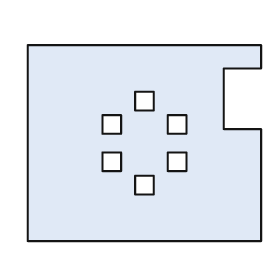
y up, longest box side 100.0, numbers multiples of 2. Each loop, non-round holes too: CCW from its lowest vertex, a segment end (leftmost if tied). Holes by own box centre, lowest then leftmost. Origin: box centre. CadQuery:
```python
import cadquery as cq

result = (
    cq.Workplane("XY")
    .moveTo(-50.0, -42.0)
    .lineTo(50.0, -42.0)
    .lineTo(50.0, 6.0)
    .lineTo(34.0, 6.0)
    .lineTo(34.0, 32.0)
    .lineTo(50.0, 32.0)
    .lineTo(50.0, 42.0)
    .lineTo(-50.0, 42.0)
    .close()
    .moveTo(-4.0, -22.0)
    .lineTo(4.0, -22.0)
    .lineTo(4.0, -14.0)
    .lineTo(-4.0, -14.0)
    .close()
    .moveTo(-18.0, -12.0)
    .lineTo(-10.0, -12.0)
    .lineTo(-10.0, -4.0)
    .lineTo(-18.0, -4.0)
    .close()
    .moveTo(10.0, -12.0)
    .lineTo(18.0, -12.0)
    .lineTo(18.0, -4.0)
    .lineTo(10.0, -4.0)
    .close()
    .moveTo(-18.0, 4.0)
    .lineTo(-10.0, 4.0)
    .lineTo(-10.0, 12.0)
    .lineTo(-18.0, 12.0)
    .close()
    .moveTo(10.0, 4.0)
    .lineTo(18.0, 4.0)
    .lineTo(18.0, 12.0)
    .lineTo(10.0, 12.0)
    .close()
    .moveTo(-4.0, 14.0)
    .lineTo(4.0, 14.0)
    .lineTo(4.0, 22.0)
    .lineTo(-4.0, 22.0)
    .close()
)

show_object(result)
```